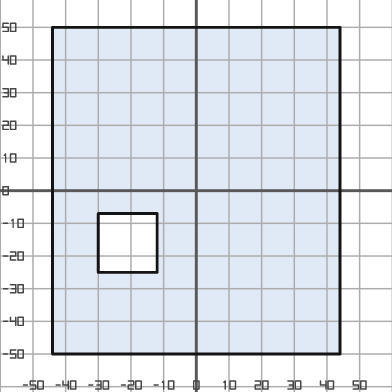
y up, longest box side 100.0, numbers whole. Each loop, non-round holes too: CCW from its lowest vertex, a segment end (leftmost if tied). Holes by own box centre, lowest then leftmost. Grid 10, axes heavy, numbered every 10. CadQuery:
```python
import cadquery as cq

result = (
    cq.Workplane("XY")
    .moveTo(-44.0, -50.0)
    .lineTo(44.0, -50.0)
    .lineTo(44.0, 50.0)
    .lineTo(-44.0, 50.0)
    .close()
    .moveTo(-30.0, -25.0)
    .lineTo(-12.0, -25.0)
    .lineTo(-12.0, -7.0)
    .lineTo(-30.0, -7.0)
    .close()
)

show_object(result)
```